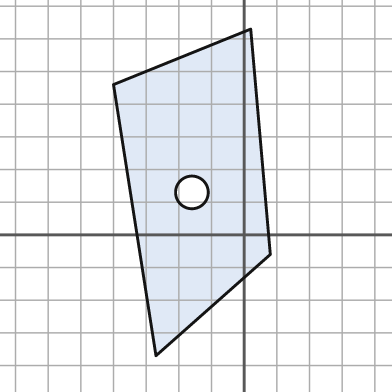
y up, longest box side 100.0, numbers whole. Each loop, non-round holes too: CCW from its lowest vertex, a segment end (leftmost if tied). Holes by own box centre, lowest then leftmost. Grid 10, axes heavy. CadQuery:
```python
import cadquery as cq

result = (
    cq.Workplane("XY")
    .moveTo(-27.0, -37.0)
    .lineTo(8.0, -6.0)
    .lineTo(2.0, 63.0)
    .lineTo(-40.0, 46.0)
    .close()
    .moveTo(-16.0, 13.0)
    .circle(5.0)
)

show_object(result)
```